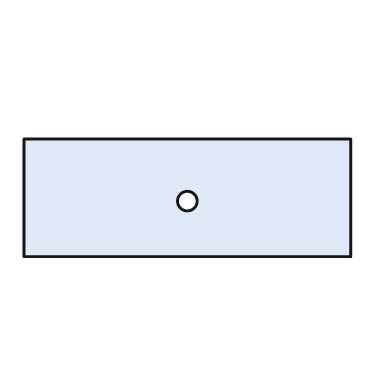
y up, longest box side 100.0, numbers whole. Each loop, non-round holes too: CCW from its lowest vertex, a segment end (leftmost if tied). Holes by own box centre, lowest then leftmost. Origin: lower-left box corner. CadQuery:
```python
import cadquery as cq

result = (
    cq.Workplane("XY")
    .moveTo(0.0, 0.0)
    .lineTo(100.0, 0.0)
    .lineTo(100.0, 36.0)
    .lineTo(0.0, 36.0)
    .close()
    .moveTo(50.0, 17.0)
    .circle(3.0)
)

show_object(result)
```